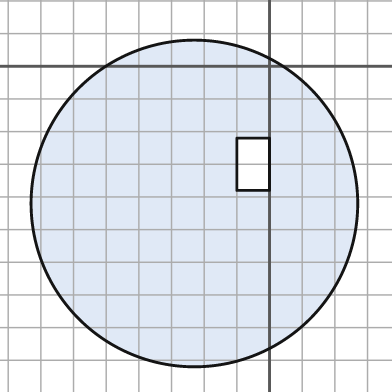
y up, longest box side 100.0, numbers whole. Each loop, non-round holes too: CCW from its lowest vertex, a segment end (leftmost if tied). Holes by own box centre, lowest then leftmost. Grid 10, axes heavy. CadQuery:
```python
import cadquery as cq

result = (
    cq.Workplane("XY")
    .moveTo(-23.0, -42.0)
    .circle(50.0)
    .moveTo(-10.0, -38.0)
    .lineTo(0.0, -38.0)
    .lineTo(0.0, -22.0)
    .lineTo(-10.0, -22.0)
    .close()
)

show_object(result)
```